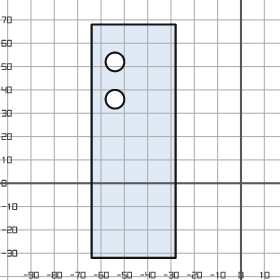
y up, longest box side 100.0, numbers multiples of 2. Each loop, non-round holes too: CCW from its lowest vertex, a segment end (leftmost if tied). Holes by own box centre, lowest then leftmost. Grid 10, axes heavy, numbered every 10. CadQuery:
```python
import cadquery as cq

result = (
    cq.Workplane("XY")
    .moveTo(-64.0, -32.0)
    .lineTo(-28.0, -32.0)
    .lineTo(-28.0, 68.0)
    .lineTo(-64.0, 68.0)
    .close()
    .moveTo(-54.0, 36.0)
    .circle(4.0)
    .moveTo(-54.0, 52.0)
    .circle(4.0)
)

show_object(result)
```